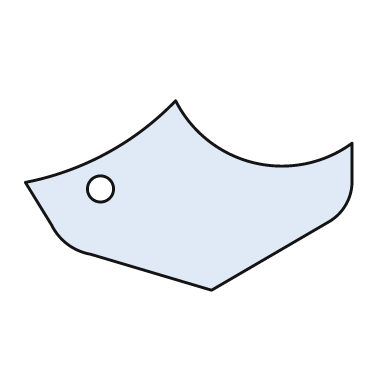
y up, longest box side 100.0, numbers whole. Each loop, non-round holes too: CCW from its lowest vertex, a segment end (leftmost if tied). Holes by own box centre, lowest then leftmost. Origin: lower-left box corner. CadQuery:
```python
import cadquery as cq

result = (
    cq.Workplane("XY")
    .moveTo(57.0, 0.0)
    .lineTo(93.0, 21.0)
    .threePointArc((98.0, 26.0), (100.0, 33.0))
    .lineTo(100.0, 45.0)
    .threePointArc((70.0, 39.0), (46.0, 58.0))
    .threePointArc((25.0, 42.0), (0.0, 33.0))
    .lineTo(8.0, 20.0)
    .threePointArc((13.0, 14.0), (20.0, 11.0))
    .close()
    .moveTo(23.0, 31.0)
    .circle(4.0)
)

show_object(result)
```